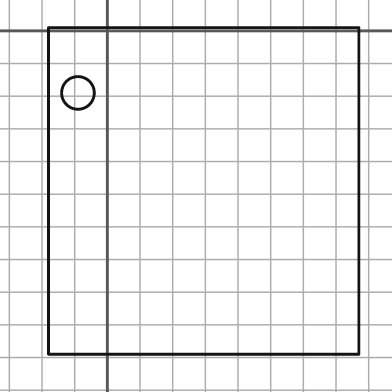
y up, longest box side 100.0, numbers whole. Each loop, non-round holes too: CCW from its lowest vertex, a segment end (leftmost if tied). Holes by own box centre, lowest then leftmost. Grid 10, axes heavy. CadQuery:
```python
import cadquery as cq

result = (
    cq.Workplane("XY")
    .moveTo(-18.0, -99.0)
    .lineTo(77.0, -99.0)
    .lineTo(77.0, 1.0)
    .lineTo(-18.0, 1.0)
    .close()
    .moveTo(-9.0, -19.0)
    .circle(5.0)
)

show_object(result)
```